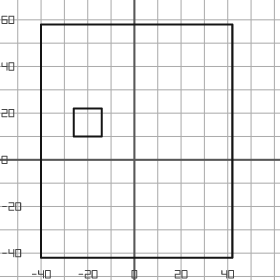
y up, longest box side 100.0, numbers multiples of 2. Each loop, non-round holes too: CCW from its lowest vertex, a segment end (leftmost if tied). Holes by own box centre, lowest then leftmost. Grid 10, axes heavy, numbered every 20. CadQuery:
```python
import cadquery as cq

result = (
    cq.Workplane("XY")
    .moveTo(-40.0, -42.0)
    .lineTo(42.0, -42.0)
    .lineTo(42.0, 58.0)
    .lineTo(-40.0, 58.0)
    .close()
    .moveTo(-26.0, 10.0)
    .lineTo(-14.0, 10.0)
    .lineTo(-14.0, 22.0)
    .lineTo(-26.0, 22.0)
    .close()
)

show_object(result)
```